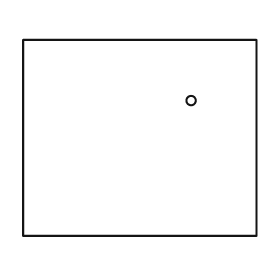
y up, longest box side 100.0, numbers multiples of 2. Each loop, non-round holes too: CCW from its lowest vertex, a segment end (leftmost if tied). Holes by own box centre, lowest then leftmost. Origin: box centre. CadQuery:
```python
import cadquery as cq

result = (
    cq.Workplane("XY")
    .moveTo(-50.0, -42.0)
    .lineTo(50.0, -42.0)
    .lineTo(50.0, 42.0)
    .lineTo(-50.0, 42.0)
    .close()
    .moveTo(22.0, 16.0)
    .circle(2.0)
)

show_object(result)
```